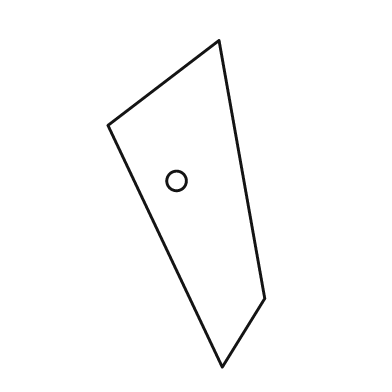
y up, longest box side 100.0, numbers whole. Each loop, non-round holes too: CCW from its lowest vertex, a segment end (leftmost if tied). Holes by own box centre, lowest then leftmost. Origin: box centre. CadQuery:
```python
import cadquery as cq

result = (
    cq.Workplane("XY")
    .moveTo(11.0, -50.0)
    .lineTo(24.0, -29.0)
    .lineTo(10.0, 50.0)
    .lineTo(-24.0, 24.0)
    .close()
    .moveTo(-3.0, 7.0)
    .circle(3.0)
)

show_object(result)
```